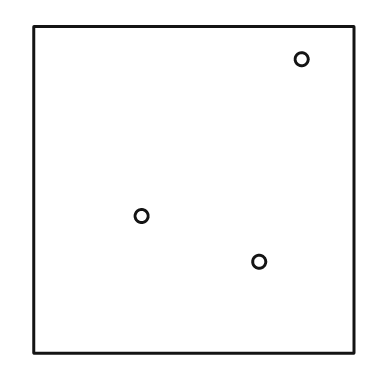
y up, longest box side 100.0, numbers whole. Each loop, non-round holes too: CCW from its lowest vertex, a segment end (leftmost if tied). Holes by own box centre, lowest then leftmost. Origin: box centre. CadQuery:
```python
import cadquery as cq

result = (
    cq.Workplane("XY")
    .moveTo(-49.0, -50.0)
    .lineTo(49.0, -50.0)
    .lineTo(49.0, 50.0)
    .lineTo(-49.0, 50.0)
    .close()
    .moveTo(20.0, -22.0)
    .circle(2.0)
    .moveTo(-16.0, -8.0)
    .circle(2.0)
    .moveTo(33.0, 40.0)
    .circle(2.0)
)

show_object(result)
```